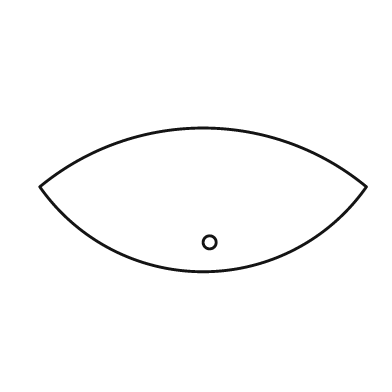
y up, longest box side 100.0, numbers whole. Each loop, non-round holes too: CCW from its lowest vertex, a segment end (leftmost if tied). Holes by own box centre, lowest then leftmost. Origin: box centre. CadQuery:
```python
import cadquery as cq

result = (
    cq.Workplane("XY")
    .moveTo(-50.0, 4.0)
    .threePointArc((0.0, -22.0), (50.0, 4.0))
    .threePointArc((0.0, 22.0), (-50.0, 4.0))
    .close()
    .moveTo(2.0, -13.0)
    .circle(2.0)
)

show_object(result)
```